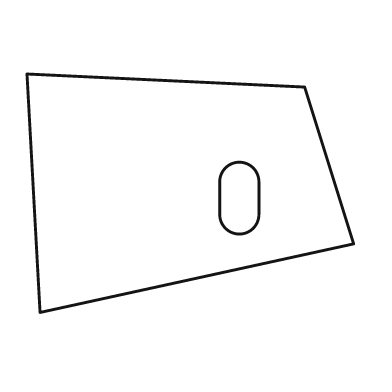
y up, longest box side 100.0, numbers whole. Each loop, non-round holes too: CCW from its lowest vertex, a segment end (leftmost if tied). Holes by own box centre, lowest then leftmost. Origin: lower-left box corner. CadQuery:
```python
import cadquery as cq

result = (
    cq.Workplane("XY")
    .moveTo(4.0, 0.0)
    .lineTo(100.0, 21.0)
    .lineTo(85.0, 69.0)
    .lineTo(0.0, 73.0)
    .close()
    .moveTo(59.0, 30.0)
    .threePointArc((65.0, 24.0), (71.0, 30.0))
    .lineTo(71.0, 40.0)
    .threePointArc((65.0, 46.0), (59.0, 40.0))
    .close()
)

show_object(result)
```